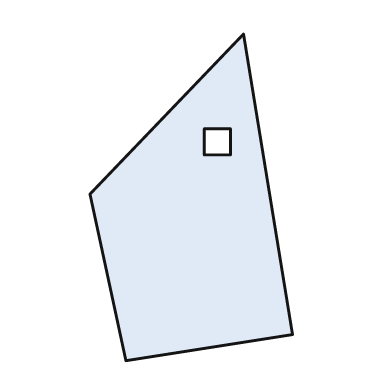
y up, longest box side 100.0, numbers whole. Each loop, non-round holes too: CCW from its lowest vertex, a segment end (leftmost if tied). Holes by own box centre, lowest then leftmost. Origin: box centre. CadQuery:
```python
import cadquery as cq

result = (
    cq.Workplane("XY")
    .moveTo(-20.0, -50.0)
    .lineTo(31.0, -42.0)
    .lineTo(16.0, 50.0)
    .lineTo(-31.0, 1.0)
    .close()
    .moveTo(4.0, 13.0)
    .lineTo(12.0, 13.0)
    .lineTo(12.0, 21.0)
    .lineTo(4.0, 21.0)
    .close()
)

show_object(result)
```